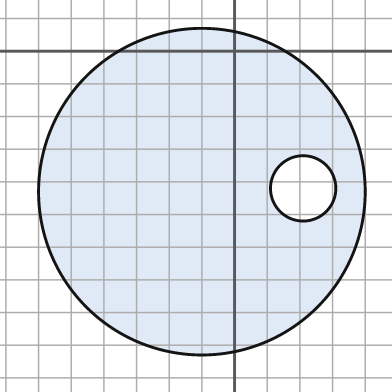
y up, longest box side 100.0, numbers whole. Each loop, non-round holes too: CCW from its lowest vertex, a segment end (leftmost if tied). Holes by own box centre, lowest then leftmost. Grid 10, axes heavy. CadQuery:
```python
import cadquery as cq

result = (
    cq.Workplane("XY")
    .moveTo(-10.0, -43.0)
    .circle(50.0)
    .moveTo(21.0, -42.0)
    .circle(10.0)
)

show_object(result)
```